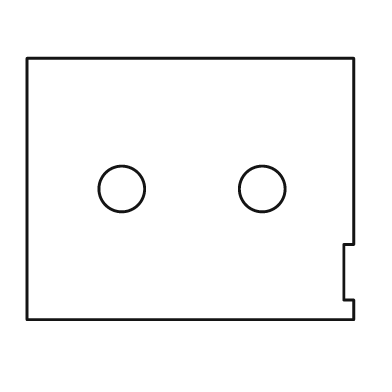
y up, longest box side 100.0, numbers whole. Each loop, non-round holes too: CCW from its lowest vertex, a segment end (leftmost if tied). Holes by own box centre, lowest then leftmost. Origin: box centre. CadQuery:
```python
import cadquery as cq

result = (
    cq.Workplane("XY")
    .moveTo(-50.0, -40.0)
    .lineTo(50.0, -40.0)
    .lineTo(50.0, -34.0)
    .lineTo(47.0, -34.0)
    .lineTo(47.0, -17.0)
    .lineTo(50.0, -17.0)
    .lineTo(50.0, 40.0)
    .lineTo(-50.0, 40.0)
    .close()
    .moveTo(-21.0, 0.0)
    .circle(7.0)
    .moveTo(22.0, 0.0)
    .circle(7.0)
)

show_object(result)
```